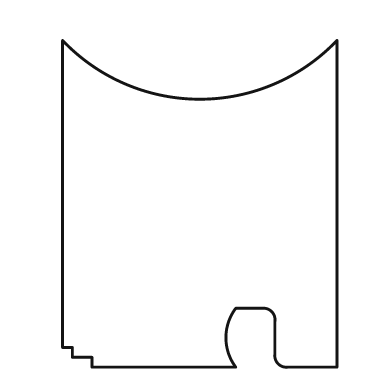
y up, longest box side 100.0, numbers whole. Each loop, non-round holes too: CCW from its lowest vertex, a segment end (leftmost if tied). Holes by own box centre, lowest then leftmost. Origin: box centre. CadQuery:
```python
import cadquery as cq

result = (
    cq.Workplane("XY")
    .moveTo(-33.0, -50.0)
    .lineTo(11.0, -50.0)
    .threePointArc((8.0, -41.0), (11.0, -32.0))
    .lineTo(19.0, -32.0)
    .threePointArc((22.0, -33.0), (23.0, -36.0))
    .lineTo(23.0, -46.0)
    .threePointArc((24.0, -49.0), (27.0, -50.0))
    .lineTo(42.0, -50.0)
    .lineTo(42.0, 50.0)
    .threePointArc((0.0, 32.0), (-42.0, 50.0))
    .lineTo(-42.0, -44.0)
    .lineTo(-39.0, -44.0)
    .lineTo(-39.0, -47.0)
    .lineTo(-33.0, -47.0)
    .close()
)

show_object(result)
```